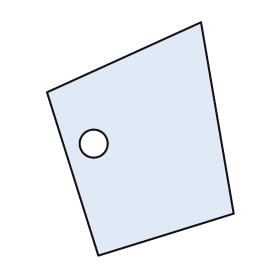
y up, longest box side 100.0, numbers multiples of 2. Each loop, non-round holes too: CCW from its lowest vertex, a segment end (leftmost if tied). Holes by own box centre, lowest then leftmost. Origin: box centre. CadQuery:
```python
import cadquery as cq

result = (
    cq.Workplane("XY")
    .moveTo(-18.0, -50.0)
    .lineTo(40.0, -32.0)
    .lineTo(26.0, 50.0)
    .lineTo(-40.0, 20.0)
    .close()
    .moveTo(-20.0, -2.0)
    .circle(6.0)
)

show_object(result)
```